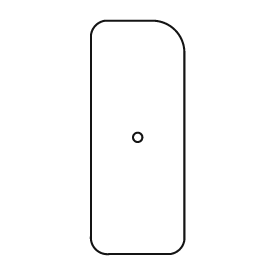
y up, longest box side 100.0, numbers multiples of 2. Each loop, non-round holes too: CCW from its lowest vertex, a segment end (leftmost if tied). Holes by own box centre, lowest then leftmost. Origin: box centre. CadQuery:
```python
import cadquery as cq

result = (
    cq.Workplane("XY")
    .moveTo(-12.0, -50.0)
    .lineTo(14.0, -50.0)
    .threePointArc((18.0, -48.0), (20.0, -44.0))
    .lineTo(20.0, 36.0)
    .threePointArc((16.0, 46.0), (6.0, 50.0))
    .lineTo(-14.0, 50.0)
    .threePointArc((-18.0, 48.0), (-20.0, 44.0))
    .lineTo(-20.0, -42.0)
    .threePointArc((-18.0, -48.0), (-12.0, -50.0))
    .close()
    .moveTo(0.0, 0.0)
    .circle(2.0)
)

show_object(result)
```